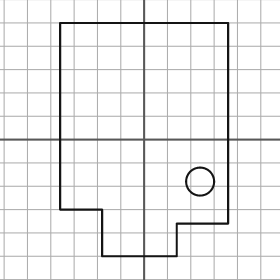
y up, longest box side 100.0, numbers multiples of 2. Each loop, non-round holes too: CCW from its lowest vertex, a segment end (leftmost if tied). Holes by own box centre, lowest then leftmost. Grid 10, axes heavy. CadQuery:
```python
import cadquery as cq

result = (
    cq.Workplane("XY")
    .moveTo(-18.0, -50.0)
    .lineTo(14.0, -50.0)
    .lineTo(14.0, -36.0)
    .lineTo(36.0, -36.0)
    .lineTo(36.0, 50.0)
    .lineTo(-36.0, 50.0)
    .lineTo(-36.0, -30.0)
    .lineTo(-18.0, -30.0)
    .close()
    .moveTo(24.0, -18.0)
    .circle(6.0)
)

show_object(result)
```